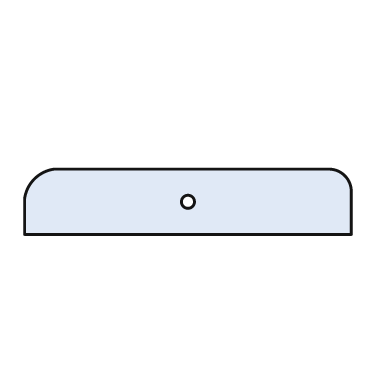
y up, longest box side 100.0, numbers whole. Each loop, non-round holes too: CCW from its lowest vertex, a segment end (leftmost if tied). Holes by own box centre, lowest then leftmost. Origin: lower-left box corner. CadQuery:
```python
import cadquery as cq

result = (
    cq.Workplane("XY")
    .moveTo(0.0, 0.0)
    .lineTo(100.0, 0.0)
    .lineTo(100.0, 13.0)
    .threePointArc((98.0, 18.0), (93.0, 20.0))
    .lineTo(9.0, 20.0)
    .threePointArc((3.0, 17.0), (0.0, 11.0))
    .close()
    .moveTo(50.0, 10.0)
    .circle(2.0)
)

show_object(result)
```